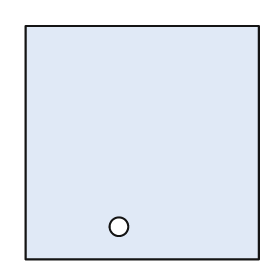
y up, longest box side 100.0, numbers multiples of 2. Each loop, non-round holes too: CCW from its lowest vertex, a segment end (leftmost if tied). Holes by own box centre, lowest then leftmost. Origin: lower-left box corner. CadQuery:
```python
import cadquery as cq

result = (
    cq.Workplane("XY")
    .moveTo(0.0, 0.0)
    .lineTo(100.0, 0.0)
    .lineTo(100.0, 100.0)
    .lineTo(0.0, 100.0)
    .close()
    .moveTo(40.0, 14.0)
    .circle(4.0)
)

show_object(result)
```